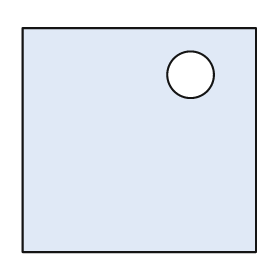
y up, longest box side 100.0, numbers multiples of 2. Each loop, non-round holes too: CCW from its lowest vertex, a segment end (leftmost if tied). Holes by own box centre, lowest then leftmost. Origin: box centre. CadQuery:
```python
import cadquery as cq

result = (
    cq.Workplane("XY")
    .moveTo(-50.0, -48.0)
    .lineTo(50.0, -48.0)
    .lineTo(50.0, 48.0)
    .lineTo(-50.0, 48.0)
    .close()
    .moveTo(22.0, 28.0)
    .circle(10.0)
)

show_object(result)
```